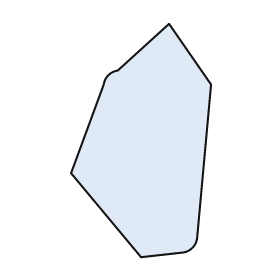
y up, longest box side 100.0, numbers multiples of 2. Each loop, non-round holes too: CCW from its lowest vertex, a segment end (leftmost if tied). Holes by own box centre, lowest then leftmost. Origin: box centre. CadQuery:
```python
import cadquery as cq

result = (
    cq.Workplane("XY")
    .moveTo(0.0, -50.0)
    .lineTo(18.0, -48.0)
    .threePointArc((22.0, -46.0), (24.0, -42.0))
    .lineTo(30.0, 24.0)
    .lineTo(12.0, 50.0)
    .lineTo(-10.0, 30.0)
    .threePointArc((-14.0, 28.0), (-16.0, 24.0))
    .lineTo(-30.0, -14.0)
    .close()
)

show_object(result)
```